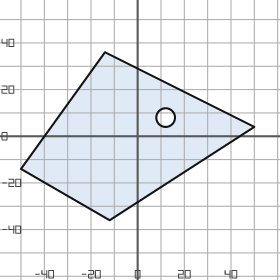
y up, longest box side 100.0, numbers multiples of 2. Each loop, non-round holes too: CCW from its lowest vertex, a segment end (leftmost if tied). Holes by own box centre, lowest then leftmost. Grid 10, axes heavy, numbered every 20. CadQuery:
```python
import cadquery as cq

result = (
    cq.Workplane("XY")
    .moveTo(-12.0, -36.0)
    .lineTo(50.0, 4.0)
    .lineTo(-14.0, 36.0)
    .lineTo(-50.0, -14.0)
    .close()
    .moveTo(12.0, 8.0)
    .circle(4.0)
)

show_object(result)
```